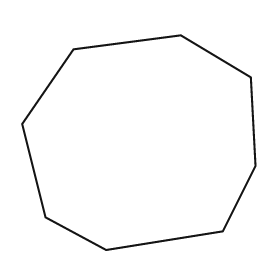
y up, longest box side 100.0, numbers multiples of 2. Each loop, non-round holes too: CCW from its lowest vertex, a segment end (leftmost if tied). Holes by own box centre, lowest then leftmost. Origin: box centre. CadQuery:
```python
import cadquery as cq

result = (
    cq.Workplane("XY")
    .moveTo(-14.0, -46.0)
    .lineTo(36.0, -38.0)
    .lineTo(50.0, -10.0)
    .lineTo(48.0, 28.0)
    .lineTo(18.0, 46.0)
    .lineTo(-28.0, 40.0)
    .lineTo(-50.0, 8.0)
    .lineTo(-40.0, -32.0)
    .close()
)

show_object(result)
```